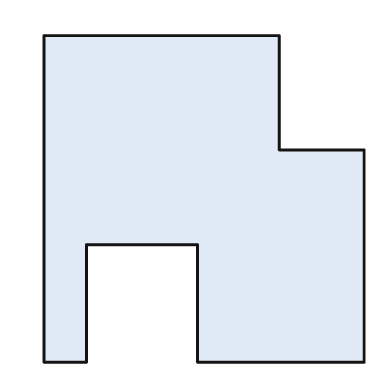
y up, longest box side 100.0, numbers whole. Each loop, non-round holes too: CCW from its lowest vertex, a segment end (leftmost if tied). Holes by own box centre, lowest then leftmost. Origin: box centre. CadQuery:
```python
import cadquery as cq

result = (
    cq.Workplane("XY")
    .moveTo(-49.0, -50.0)
    .lineTo(-36.0, -50.0)
    .lineTo(-36.0, -14.0)
    .lineTo(-2.0, -14.0)
    .lineTo(-2.0, -50.0)
    .lineTo(49.0, -50.0)
    .lineTo(49.0, 15.0)
    .lineTo(23.0, 15.0)
    .lineTo(23.0, 50.0)
    .lineTo(-49.0, 50.0)
    .close()
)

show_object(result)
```